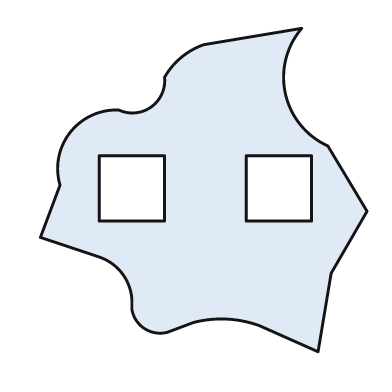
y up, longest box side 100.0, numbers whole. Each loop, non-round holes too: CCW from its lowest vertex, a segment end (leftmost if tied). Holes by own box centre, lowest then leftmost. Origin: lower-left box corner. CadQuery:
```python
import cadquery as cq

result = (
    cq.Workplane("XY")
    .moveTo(85.0, 0.0)
    .lineTo(89.0, 24.0)
    .lineTo(100.0, 43.0)
    .lineTo(88.0, 63.0)
    .threePointArc((75.0, 79.0), (80.0, 99.0))
    .lineTo(50.0, 94.0)
    .threePointArc((43.0, 90.0), (38.0, 84.0))
    .threePointArc((34.0, 75.0), (24.0, 74.0))
    .threePointArc((9.0, 67.0), (6.0, 51.0))
    .lineTo(0.0, 35.0)
    .lineTo(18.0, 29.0)
    .threePointArc((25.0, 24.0), (28.0, 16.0))
    .lineTo(28.0, 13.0)
    .threePointArc((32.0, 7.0), (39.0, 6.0))
    .lineTo(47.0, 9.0)
    .threePointArc((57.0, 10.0), (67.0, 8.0))
    .close()
    .moveTo(18.0, 40.0)
    .lineTo(38.0, 40.0)
    .lineTo(38.0, 60.0)
    .lineTo(18.0, 60.0)
    .close()
    .moveTo(63.0, 40.0)
    .lineTo(83.0, 40.0)
    .lineTo(83.0, 60.0)
    .lineTo(63.0, 60.0)
    .close()
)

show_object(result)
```